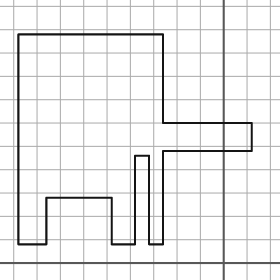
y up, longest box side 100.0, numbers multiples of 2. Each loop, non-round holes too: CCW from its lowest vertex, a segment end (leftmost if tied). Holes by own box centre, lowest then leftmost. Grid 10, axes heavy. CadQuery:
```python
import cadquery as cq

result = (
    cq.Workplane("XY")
    .moveTo(-88.0, 8.0)
    .lineTo(-76.0, 8.0)
    .lineTo(-76.0, 28.0)
    .lineTo(-48.0, 28.0)
    .lineTo(-48.0, 8.0)
    .lineTo(-38.0, 8.0)
    .lineTo(-38.0, 46.0)
    .lineTo(-32.0, 46.0)
    .lineTo(-32.0, 8.0)
    .lineTo(-26.0, 8.0)
    .lineTo(-26.0, 48.0)
    .lineTo(12.0, 48.0)
    .lineTo(12.0, 60.0)
    .lineTo(-26.0, 60.0)
    .lineTo(-26.0, 98.0)
    .lineTo(-88.0, 98.0)
    .close()
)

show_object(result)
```